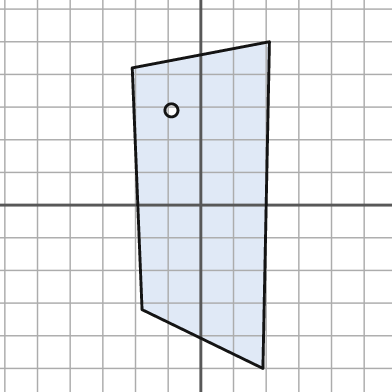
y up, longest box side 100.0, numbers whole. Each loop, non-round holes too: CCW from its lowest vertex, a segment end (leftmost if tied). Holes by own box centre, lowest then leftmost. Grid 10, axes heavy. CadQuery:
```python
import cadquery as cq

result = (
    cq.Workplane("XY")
    .moveTo(19.0, -50.0)
    .lineTo(21.0, 50.0)
    .lineTo(-21.0, 42.0)
    .lineTo(-18.0, -32.0)
    .close()
    .moveTo(-9.0, 29.0)
    .circle(2.0)
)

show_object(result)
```